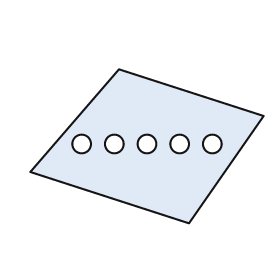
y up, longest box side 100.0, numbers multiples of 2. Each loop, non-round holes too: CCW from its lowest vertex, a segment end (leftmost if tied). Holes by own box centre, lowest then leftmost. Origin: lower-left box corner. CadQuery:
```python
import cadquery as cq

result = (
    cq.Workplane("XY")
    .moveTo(68.0, 0.0)
    .lineTo(100.0, 46.0)
    .lineTo(38.0, 66.0)
    .lineTo(0.0, 22.0)
    .close()
    .moveTo(22.0, 34.0)
    .circle(4.0)
    .moveTo(36.0, 34.0)
    .circle(4.0)
    .moveTo(50.0, 34.0)
    .circle(4.0)
    .moveTo(64.0, 34.0)
    .circle(4.0)
    .moveTo(78.0, 34.0)
    .circle(4.0)
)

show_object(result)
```